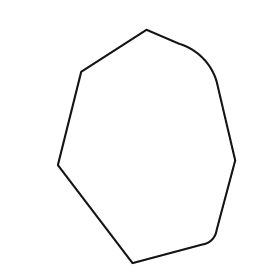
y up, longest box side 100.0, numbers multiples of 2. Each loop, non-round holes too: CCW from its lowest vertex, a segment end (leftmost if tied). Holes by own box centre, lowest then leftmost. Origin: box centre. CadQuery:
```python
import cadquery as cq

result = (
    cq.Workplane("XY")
    .moveTo(-6.0, -50.0)
    .lineTo(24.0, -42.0)
    .threePointArc((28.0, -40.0), (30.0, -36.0))
    .lineTo(38.0, -6.0)
    .lineTo(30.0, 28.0)
    .threePointArc((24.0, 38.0), (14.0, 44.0))
    .lineTo(0.0, 50.0)
    .lineTo(-28.0, 32.0)
    .lineTo(-38.0, -8.0)
    .close()
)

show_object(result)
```